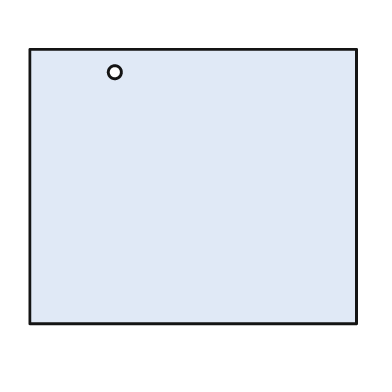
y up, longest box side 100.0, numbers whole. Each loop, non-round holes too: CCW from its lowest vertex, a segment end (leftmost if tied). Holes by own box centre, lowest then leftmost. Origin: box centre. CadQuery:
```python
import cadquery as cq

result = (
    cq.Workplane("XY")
    .moveTo(-50.0, -42.0)
    .lineTo(50.0, -42.0)
    .lineTo(50.0, 42.0)
    .lineTo(-50.0, 42.0)
    .close()
    .moveTo(-24.0, 35.0)
    .circle(2.0)
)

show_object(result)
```